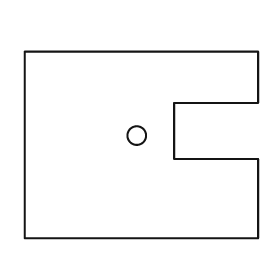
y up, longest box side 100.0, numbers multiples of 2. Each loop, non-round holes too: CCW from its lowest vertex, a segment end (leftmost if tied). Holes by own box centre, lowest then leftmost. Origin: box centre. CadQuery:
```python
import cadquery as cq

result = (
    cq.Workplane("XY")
    .moveTo(-50.0, -40.0)
    .lineTo(50.0, -40.0)
    .lineTo(50.0, -6.0)
    .lineTo(14.0, -6.0)
    .lineTo(14.0, 18.0)
    .lineTo(50.0, 18.0)
    .lineTo(50.0, 40.0)
    .lineTo(-50.0, 40.0)
    .close()
    .moveTo(-2.0, 4.0)
    .circle(4.0)
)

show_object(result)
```